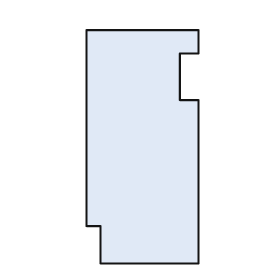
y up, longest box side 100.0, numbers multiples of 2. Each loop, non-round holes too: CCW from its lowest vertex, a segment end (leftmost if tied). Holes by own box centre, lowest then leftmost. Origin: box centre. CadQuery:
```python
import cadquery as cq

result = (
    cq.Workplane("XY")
    .moveTo(-18.0, -50.0)
    .lineTo(24.0, -50.0)
    .lineTo(24.0, 20.0)
    .lineTo(16.0, 20.0)
    .lineTo(16.0, 40.0)
    .lineTo(24.0, 40.0)
    .lineTo(24.0, 50.0)
    .lineTo(-24.0, 50.0)
    .lineTo(-24.0, -34.0)
    .lineTo(-18.0, -34.0)
    .close()
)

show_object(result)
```